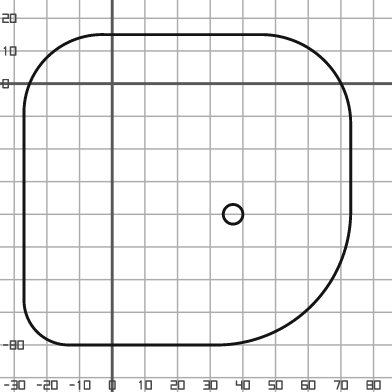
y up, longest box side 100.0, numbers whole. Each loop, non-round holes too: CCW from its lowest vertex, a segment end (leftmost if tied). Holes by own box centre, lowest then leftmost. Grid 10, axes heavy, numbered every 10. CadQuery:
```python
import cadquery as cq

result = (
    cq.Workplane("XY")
    .moveTo(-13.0, -80.0)
    .lineTo(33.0, -80.0)
    .threePointArc((61.0, -68.0), (73.0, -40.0))
    .lineTo(73.0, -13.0)
    .threePointArc((65.0, 7.0), (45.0, 15.0))
    .lineTo(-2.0, 15.0)
    .threePointArc((-20.0, 8.0), (-27.0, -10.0))
    .lineTo(-27.0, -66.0)
    .threePointArc((-23.0, -76.0), (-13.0, -80.0))
    .close()
    .moveTo(37.0, -40.0)
    .circle(3.0)
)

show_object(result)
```